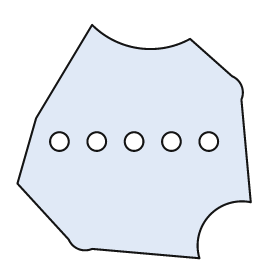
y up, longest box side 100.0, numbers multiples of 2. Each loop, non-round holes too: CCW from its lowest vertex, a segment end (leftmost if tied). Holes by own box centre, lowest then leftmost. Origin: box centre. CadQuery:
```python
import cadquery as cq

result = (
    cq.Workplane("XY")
    .moveTo(28.0, -50.0)
    .threePointArc((32.0, -32.0), (50.0, -26.0))
    .lineTo(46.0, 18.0)
    .threePointArc((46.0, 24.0), (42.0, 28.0))
    .lineTo(24.0, 44.0)
    .threePointArc((2.0, 40.0), (-18.0, 50.0))
    .lineTo(-42.0, 10.0)
    .lineTo(-50.0, -18.0)
    .lineTo(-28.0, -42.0)
    .threePointArc((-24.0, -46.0), (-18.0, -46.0))
    .close()
    .moveTo(-32.0, 0.0)
    .circle(4.0)
    .moveTo(-16.0, 0.0)
    .circle(4.0)
    .moveTo(0.0, 0.0)
    .circle(4.0)
    .moveTo(16.0, 0.0)
    .circle(4.0)
    .moveTo(32.0, 0.0)
    .circle(4.0)
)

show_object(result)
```